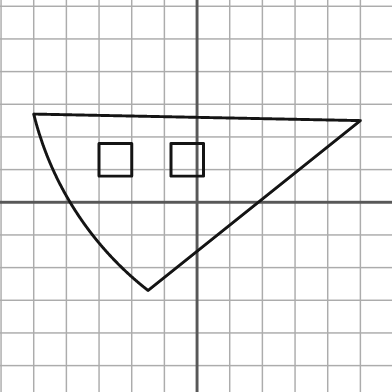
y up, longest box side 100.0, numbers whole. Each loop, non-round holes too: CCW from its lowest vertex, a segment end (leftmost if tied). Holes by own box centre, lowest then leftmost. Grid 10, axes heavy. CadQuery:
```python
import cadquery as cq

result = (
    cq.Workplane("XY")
    .moveTo(-15.0, -27.0)
    .lineTo(50.0, 25.0)
    .lineTo(-50.0, 27.0)
    .threePointArc((-37.0, -3.0), (-15.0, -27.0))
    .close()
    .moveTo(-30.0, 8.0)
    .lineTo(-20.0, 8.0)
    .lineTo(-20.0, 18.0)
    .lineTo(-30.0, 18.0)
    .close()
    .moveTo(-8.0, 8.0)
    .lineTo(2.0, 8.0)
    .lineTo(2.0, 18.0)
    .lineTo(-8.0, 18.0)
    .close()
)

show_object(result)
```